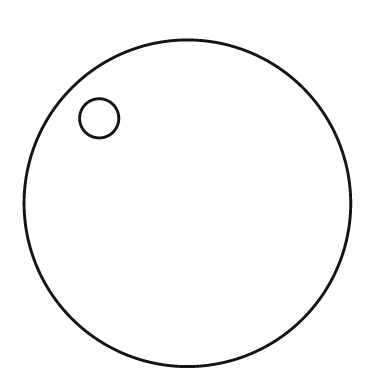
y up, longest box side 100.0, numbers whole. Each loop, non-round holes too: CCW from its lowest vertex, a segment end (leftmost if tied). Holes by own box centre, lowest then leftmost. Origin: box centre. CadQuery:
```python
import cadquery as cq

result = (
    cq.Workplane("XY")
    .moveTo(0.0, 0.0)
    .circle(50.0)
    .moveTo(-27.0, 26.0)
    .circle(6.0)
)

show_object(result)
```